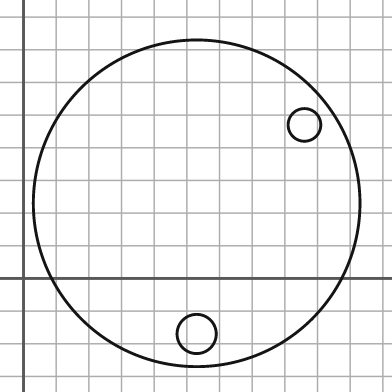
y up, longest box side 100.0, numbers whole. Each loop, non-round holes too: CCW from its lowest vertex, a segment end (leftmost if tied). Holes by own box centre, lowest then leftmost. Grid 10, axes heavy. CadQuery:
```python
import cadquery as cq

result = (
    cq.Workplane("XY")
    .moveTo(53.0, 23.0)
    .circle(50.0)
    .moveTo(53.0, -17.0)
    .circle(6.0)
    .moveTo(86.0, 47.0)
    .circle(5.0)
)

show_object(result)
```